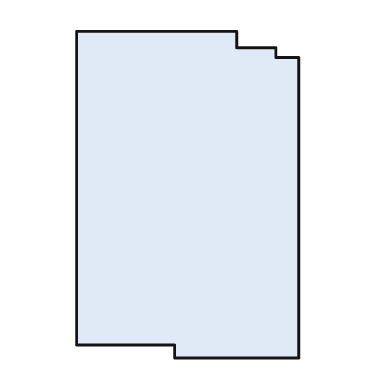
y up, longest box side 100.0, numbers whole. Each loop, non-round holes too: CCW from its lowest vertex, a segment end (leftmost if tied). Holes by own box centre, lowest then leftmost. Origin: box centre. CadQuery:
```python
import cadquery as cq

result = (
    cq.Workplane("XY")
    .moveTo(-4.0, -50.0)
    .lineTo(34.0, -50.0)
    .lineTo(34.0, 42.0)
    .lineTo(27.0, 42.0)
    .lineTo(27.0, 45.0)
    .lineTo(15.0, 45.0)
    .lineTo(15.0, 50.0)
    .lineTo(-34.0, 50.0)
    .lineTo(-34.0, -46.0)
    .lineTo(-4.0, -46.0)
    .close()
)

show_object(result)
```